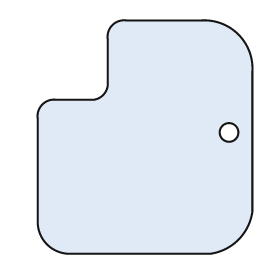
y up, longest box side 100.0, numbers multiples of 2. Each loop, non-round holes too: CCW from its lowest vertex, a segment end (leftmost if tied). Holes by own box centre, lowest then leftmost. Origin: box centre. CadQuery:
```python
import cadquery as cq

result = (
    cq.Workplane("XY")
    .moveTo(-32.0, -50.0)
    .lineTo(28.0, -50.0)
    .threePointArc((40.0, -44.0), (46.0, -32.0))
    .lineTo(46.0, 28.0)
    .threePointArc((40.0, 44.0), (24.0, 50.0))
    .lineTo(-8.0, 50.0)
    .threePointArc((-14.0, 48.0), (-16.0, 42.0))
    .lineTo(-16.0, 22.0)
    .threePointArc((-18.0, 18.0), (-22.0, 16.0))
    .lineTo(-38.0, 16.0)
    .threePointArc((-44.0, 14.0), (-46.0, 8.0))
    .lineTo(-46.0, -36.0)
    .threePointArc((-42.0, -46.0), (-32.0, -50.0))
    .close()
    .moveTo(36.0, 2.0)
    .circle(4.0)
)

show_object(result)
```